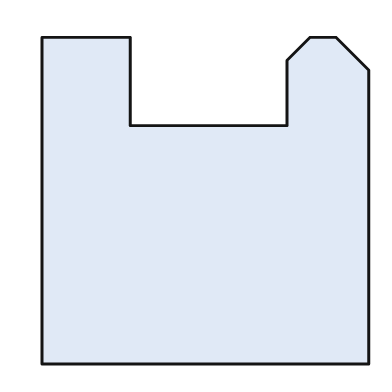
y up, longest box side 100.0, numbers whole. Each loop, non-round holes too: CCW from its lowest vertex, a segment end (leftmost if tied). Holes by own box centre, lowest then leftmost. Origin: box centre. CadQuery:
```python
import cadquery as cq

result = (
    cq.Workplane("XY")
    .moveTo(-50.0, -50.0)
    .lineTo(50.0, -50.0)
    .lineTo(50.0, 40.0)
    .lineTo(40.0, 50.0)
    .lineTo(32.0, 50.0)
    .lineTo(25.0, 43.0)
    .lineTo(25.0, 23.0)
    .lineTo(-23.0, 23.0)
    .lineTo(-23.0, 50.0)
    .lineTo(-50.0, 50.0)
    .close()
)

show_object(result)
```